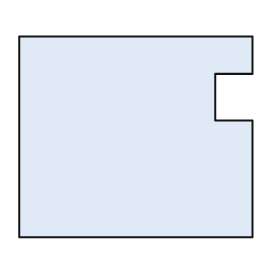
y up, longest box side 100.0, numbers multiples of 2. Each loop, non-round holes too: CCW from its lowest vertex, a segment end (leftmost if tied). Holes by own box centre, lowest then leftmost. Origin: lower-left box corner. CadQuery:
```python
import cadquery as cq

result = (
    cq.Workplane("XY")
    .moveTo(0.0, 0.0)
    .lineTo(100.0, 0.0)
    .lineTo(100.0, 50.0)
    .lineTo(84.0, 50.0)
    .lineTo(84.0, 70.0)
    .lineTo(100.0, 70.0)
    .lineTo(100.0, 86.0)
    .lineTo(0.0, 86.0)
    .close()
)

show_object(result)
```